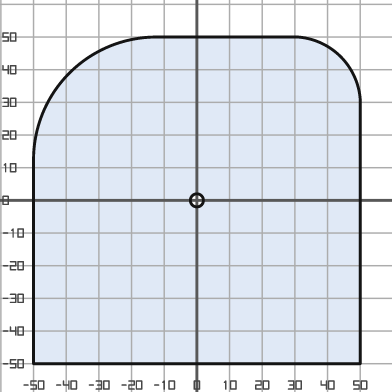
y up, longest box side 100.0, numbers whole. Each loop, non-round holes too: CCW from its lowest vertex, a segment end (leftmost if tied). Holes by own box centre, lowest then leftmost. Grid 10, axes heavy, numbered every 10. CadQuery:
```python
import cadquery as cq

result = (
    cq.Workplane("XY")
    .moveTo(-50.0, -50.0)
    .lineTo(50.0, -50.0)
    .lineTo(50.0, 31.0)
    .threePointArc((44.0, 44.0), (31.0, 50.0))
    .lineTo(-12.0, 50.0)
    .threePointArc((-39.0, 39.0), (-50.0, 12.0))
    .close()
    .moveTo(0.0, 0.0)
    .circle(2.0)
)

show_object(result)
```